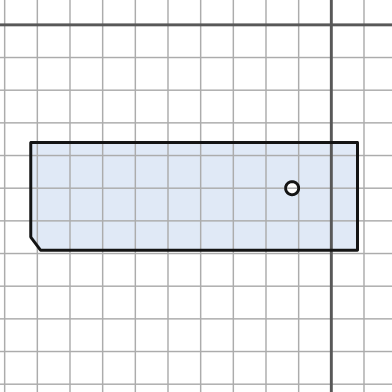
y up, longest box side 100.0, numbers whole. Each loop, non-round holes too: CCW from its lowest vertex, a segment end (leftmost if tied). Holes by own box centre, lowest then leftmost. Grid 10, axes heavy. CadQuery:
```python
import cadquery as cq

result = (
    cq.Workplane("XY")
    .moveTo(-89.0, -69.0)
    .lineTo(8.0, -69.0)
    .lineTo(8.0, -36.0)
    .lineTo(-92.0, -36.0)
    .lineTo(-92.0, -65.0)
    .close()
    .moveTo(-12.0, -50.0)
    .circle(2.0)
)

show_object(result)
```